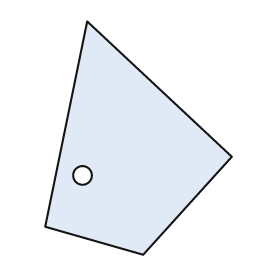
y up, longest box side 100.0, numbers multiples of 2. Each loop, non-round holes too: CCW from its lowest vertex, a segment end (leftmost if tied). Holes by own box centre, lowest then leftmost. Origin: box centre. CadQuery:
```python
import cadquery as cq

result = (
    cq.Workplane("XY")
    .moveTo(2.0, -50.0)
    .lineTo(40.0, -8.0)
    .lineTo(-22.0, 50.0)
    .lineTo(-40.0, -38.0)
    .close()
    .moveTo(-24.0, -16.0)
    .circle(4.0)
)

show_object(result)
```